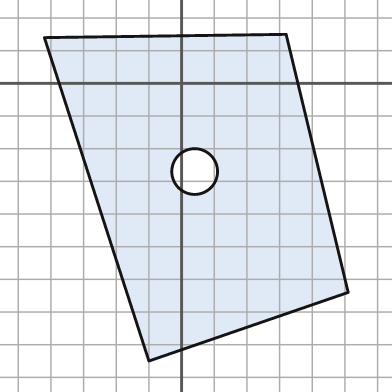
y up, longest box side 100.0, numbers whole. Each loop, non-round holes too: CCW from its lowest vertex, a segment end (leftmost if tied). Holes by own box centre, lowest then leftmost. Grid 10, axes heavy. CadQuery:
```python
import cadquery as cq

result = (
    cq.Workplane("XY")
    .moveTo(-10.0, -85.0)
    .lineTo(51.0, -64.0)
    .lineTo(32.0, 15.0)
    .lineTo(-42.0, 14.0)
    .close()
    .moveTo(4.0, -27.0)
    .circle(7.0)
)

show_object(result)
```